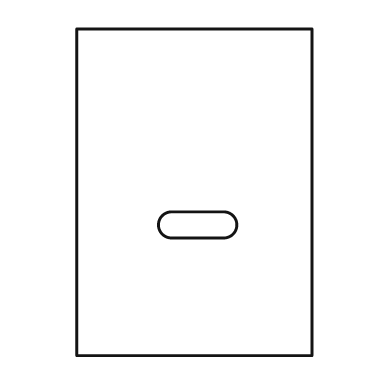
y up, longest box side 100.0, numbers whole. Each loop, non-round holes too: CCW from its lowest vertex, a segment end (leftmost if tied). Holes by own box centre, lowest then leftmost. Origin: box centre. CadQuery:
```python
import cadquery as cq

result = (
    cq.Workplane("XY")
    .moveTo(-36.0, -50.0)
    .lineTo(36.0, -50.0)
    .lineTo(36.0, 50.0)
    .lineTo(-36.0, 50.0)
    .close()
    .moveTo(-7.0, -14.0)
    .lineTo(9.0, -14.0)
    .threePointArc((13.0, -10.0), (9.0, -6.0))
    .lineTo(-7.0, -6.0)
    .threePointArc((-11.0, -10.0), (-7.0, -14.0))
    .close()
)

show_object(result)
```